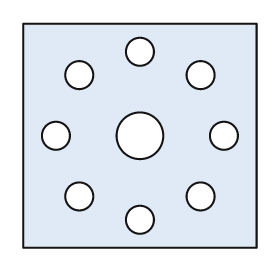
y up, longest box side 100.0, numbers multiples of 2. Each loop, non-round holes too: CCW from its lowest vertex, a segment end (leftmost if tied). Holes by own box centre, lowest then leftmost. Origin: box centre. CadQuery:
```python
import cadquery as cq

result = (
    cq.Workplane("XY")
    .moveTo(-50.0, -48.0)
    .lineTo(50.0, -48.0)
    .lineTo(50.0, 48.0)
    .lineTo(-50.0, 48.0)
    .close()
    .moveTo(0.0, -36.0)
    .circle(6.0)
    .moveTo(-26.0, -26.0)
    .circle(6.0)
    .moveTo(26.0, -26.0)
    .circle(6.0)
    .moveTo(-36.0, 0.0)
    .circle(6.0)
    .moveTo(0.0, 0.0)
    .circle(10.0)
    .moveTo(36.0, 0.0)
    .circle(6.0)
    .moveTo(-26.0, 26.0)
    .circle(6.0)
    .moveTo(26.0, 26.0)
    .circle(6.0)
    .moveTo(0.0, 36.0)
    .circle(6.0)
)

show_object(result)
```